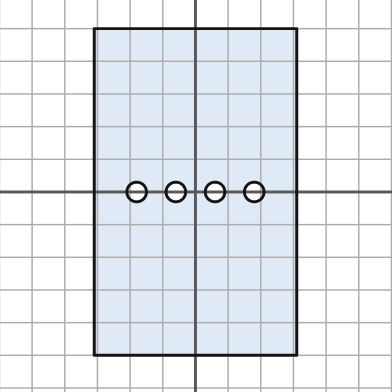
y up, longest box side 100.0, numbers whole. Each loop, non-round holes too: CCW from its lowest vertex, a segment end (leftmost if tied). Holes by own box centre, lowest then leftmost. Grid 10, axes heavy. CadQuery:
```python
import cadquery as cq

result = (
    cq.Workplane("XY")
    .moveTo(-31.0, -50.0)
    .lineTo(31.0, -50.0)
    .lineTo(31.0, 50.0)
    .lineTo(-31.0, 50.0)
    .close()
    .moveTo(-18.0, 0.0)
    .circle(3.0)
    .moveTo(-6.0, 0.0)
    .circle(3.0)
    .moveTo(6.0, 0.0)
    .circle(3.0)
    .moveTo(18.0, 0.0)
    .circle(3.0)
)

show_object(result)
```